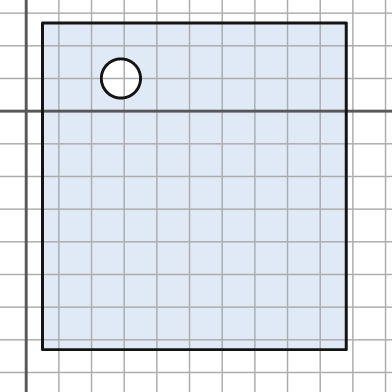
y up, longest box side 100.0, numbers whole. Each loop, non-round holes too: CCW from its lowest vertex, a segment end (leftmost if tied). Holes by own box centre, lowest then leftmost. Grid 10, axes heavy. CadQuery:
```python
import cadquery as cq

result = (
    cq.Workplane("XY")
    .moveTo(5.0, -73.0)
    .lineTo(98.0, -73.0)
    .lineTo(98.0, 27.0)
    .lineTo(5.0, 27.0)
    .close()
    .moveTo(29.0, 10.0)
    .circle(6.0)
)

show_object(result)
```